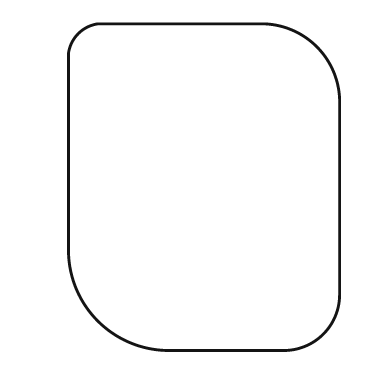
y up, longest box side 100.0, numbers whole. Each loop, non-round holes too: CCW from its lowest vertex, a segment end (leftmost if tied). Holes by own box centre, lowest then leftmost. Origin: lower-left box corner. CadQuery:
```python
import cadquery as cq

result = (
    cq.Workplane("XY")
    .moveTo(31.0, 0.0)
    .lineTo(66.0, 0.0)
    .threePointArc((78.0, 5.0), (83.0, 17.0))
    .lineTo(83.0, 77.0)
    .threePointArc((76.0, 93.0), (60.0, 100.0))
    .lineTo(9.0, 100.0)
    .threePointArc((3.0, 97.0), (0.0, 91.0))
    .lineTo(0.0, 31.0)
    .threePointArc((9.0, 9.0), (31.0, 0.0))
    .close()
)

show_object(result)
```